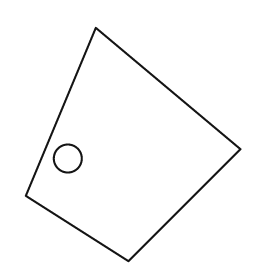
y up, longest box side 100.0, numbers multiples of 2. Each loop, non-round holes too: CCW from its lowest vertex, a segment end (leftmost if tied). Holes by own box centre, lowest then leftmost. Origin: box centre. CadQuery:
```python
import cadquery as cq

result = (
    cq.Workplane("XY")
    .moveTo(-2.0, -50.0)
    .lineTo(46.0, -2.0)
    .lineTo(-16.0, 50.0)
    .lineTo(-46.0, -22.0)
    .close()
    .moveTo(-28.0, -6.0)
    .circle(6.0)
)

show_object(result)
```